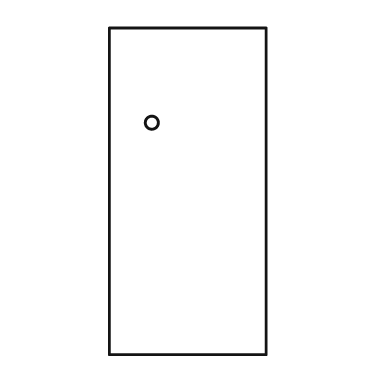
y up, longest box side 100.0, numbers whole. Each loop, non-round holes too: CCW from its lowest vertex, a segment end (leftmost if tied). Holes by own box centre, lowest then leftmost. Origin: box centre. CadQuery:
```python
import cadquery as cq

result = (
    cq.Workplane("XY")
    .moveTo(-24.0, -50.0)
    .lineTo(24.0, -50.0)
    .lineTo(24.0, 50.0)
    .lineTo(-24.0, 50.0)
    .close()
    .moveTo(-11.0, 21.0)
    .circle(2.0)
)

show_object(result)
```